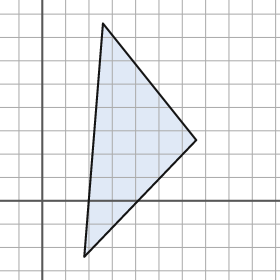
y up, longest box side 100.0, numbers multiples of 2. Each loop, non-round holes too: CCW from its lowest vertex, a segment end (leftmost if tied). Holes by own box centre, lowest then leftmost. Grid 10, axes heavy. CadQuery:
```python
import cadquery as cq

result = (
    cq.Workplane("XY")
    .moveTo(18.0, -24.0)
    .lineTo(66.0, 26.0)
    .lineTo(26.0, 76.0)
    .close()
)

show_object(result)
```